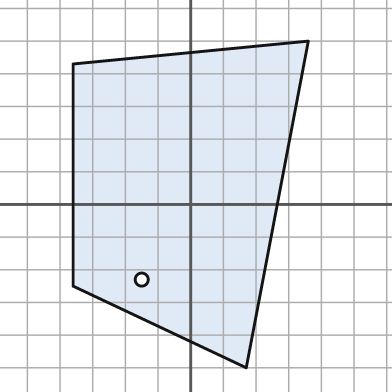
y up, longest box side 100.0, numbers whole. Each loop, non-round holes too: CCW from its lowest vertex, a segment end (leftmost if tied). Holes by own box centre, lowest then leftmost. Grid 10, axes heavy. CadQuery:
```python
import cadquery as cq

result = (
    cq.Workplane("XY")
    .moveTo(17.0, -50.0)
    .lineTo(36.0, 50.0)
    .lineTo(-36.0, 43.0)
    .lineTo(-36.0, -25.0)
    .close()
    .moveTo(-15.0, -23.0)
    .circle(2.0)
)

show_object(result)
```